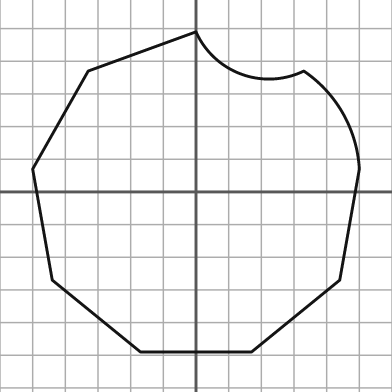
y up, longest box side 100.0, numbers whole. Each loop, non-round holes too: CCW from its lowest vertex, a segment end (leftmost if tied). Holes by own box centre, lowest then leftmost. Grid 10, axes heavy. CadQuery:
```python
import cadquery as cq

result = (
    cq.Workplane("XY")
    .moveTo(-17.0, -49.0)
    .lineTo(17.0, -49.0)
    .lineTo(44.0, -27.0)
    .lineTo(50.0, 7.0)
    .threePointArc((45.0, 24.0), (33.0, 37.0))
    .threePointArc((14.0, 36.0), (0.0, 49.0))
    .lineTo(-33.0, 37.0)
    .lineTo(-50.0, 7.0)
    .lineTo(-44.0, -27.0)
    .close()
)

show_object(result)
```